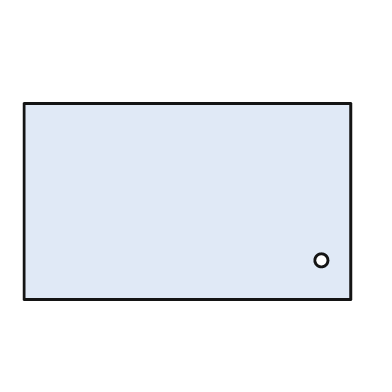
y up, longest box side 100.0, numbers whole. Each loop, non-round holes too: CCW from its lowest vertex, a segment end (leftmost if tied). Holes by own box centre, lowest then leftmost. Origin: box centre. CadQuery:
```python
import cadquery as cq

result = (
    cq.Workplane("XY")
    .moveTo(-50.0, -30.0)
    .lineTo(50.0, -30.0)
    .lineTo(50.0, 30.0)
    .lineTo(-50.0, 30.0)
    .close()
    .moveTo(41.0, -18.0)
    .circle(2.0)
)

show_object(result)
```